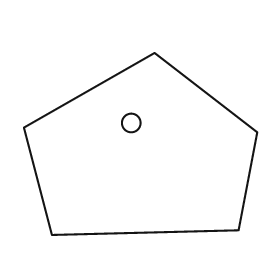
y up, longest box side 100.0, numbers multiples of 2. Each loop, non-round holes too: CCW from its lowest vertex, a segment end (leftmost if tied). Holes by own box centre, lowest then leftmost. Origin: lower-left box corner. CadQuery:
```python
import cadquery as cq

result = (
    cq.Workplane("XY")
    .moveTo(12.0, 0.0)
    .lineTo(92.0, 2.0)
    .lineTo(100.0, 44.0)
    .lineTo(56.0, 78.0)
    .lineTo(0.0, 46.0)
    .close()
    .moveTo(46.0, 48.0)
    .circle(4.0)
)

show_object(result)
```